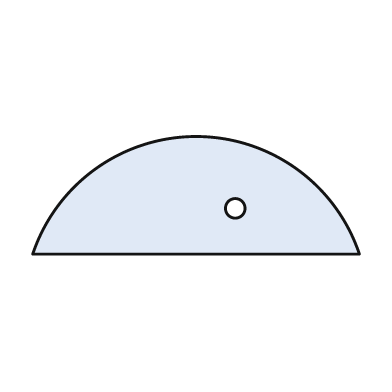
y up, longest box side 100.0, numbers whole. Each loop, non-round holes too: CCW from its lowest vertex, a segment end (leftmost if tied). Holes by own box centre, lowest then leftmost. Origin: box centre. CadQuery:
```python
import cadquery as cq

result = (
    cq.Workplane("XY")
    .moveTo(-50.0, -18.0)
    .lineTo(50.0, -18.0)
    .threePointArc((0.0, 18.0), (-50.0, -18.0))
    .close()
    .moveTo(12.0, -4.0)
    .circle(3.0)
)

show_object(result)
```